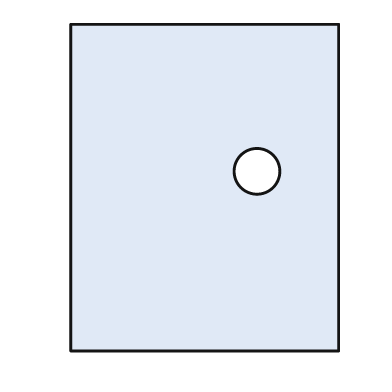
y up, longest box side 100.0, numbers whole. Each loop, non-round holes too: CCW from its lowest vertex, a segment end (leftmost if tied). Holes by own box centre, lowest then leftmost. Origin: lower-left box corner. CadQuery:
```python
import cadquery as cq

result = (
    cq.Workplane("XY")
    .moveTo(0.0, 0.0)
    .lineTo(82.0, 0.0)
    .lineTo(82.0, 100.0)
    .lineTo(0.0, 100.0)
    .close()
    .moveTo(57.0, 55.0)
    .circle(7.0)
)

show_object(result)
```